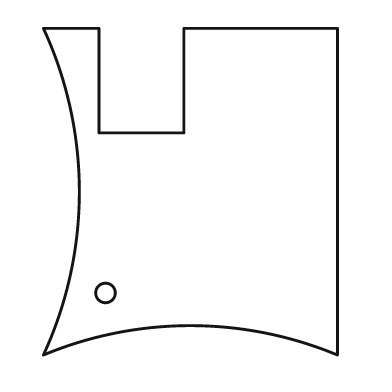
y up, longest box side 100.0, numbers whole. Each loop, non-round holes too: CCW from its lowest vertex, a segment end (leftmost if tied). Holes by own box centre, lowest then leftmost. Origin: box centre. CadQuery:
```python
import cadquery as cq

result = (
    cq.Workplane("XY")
    .moveTo(-45.0, -50.0)
    .threePointArc((0.0, -41.0), (45.0, -50.0))
    .lineTo(45.0, 50.0)
    .lineTo(-2.0, 50.0)
    .lineTo(-2.0, 18.0)
    .lineTo(-28.0, 18.0)
    .lineTo(-28.0, 50.0)
    .lineTo(-45.0, 50.0)
    .threePointArc((-34.0, 0.0), (-45.0, -50.0))
    .close()
    .moveTo(-26.0, -31.0)
    .circle(3.0)
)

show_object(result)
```